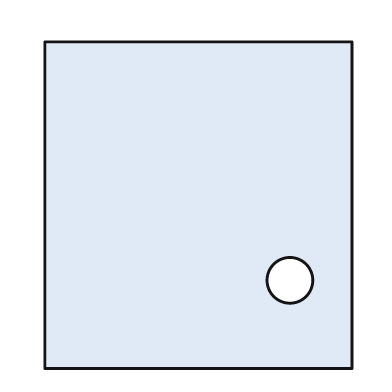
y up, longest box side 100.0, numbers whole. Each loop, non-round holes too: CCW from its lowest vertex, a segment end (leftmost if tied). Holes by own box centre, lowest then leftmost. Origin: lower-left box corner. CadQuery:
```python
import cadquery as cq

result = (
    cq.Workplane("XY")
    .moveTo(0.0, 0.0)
    .lineTo(94.0, 0.0)
    .lineTo(94.0, 100.0)
    .lineTo(0.0, 100.0)
    .close()
    .moveTo(75.0, 27.0)
    .circle(7.0)
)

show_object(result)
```